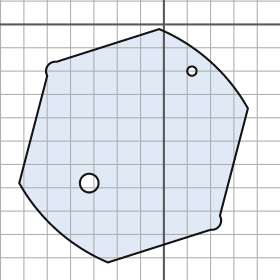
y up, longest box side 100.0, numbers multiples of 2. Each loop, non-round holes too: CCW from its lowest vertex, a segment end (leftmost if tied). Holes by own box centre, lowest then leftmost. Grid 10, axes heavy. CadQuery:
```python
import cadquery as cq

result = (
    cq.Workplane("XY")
    .moveTo(-24.0, -102.0)
    .lineTo(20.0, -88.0)
    .threePointArc((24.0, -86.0), (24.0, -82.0))
    .lineTo(36.0, -36.0)
    .threePointArc((20.0, -16.0), (-2.0, -2.0))
    .lineTo(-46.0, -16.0)
    .threePointArc((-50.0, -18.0), (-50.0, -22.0))
    .lineTo(-62.0, -68.0)
    .threePointArc((-46.0, -88.0), (-24.0, -102.0))
    .close()
    .moveTo(-32.0, -68.0)
    .circle(4.0)
    .moveTo(12.0, -20.0)
    .circle(2.0)
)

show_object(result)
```